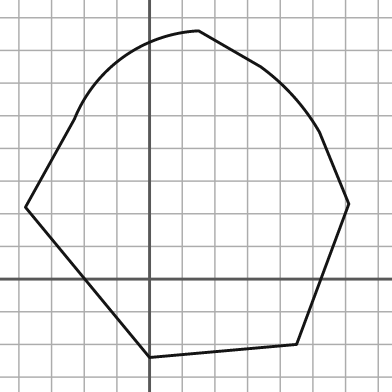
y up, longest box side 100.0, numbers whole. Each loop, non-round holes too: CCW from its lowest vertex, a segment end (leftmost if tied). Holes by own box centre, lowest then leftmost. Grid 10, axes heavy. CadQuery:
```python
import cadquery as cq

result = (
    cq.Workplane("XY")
    .moveTo(0.0, -24.0)
    .lineTo(45.0, -20.0)
    .lineTo(61.0, 23.0)
    .lineTo(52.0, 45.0)
    .threePointArc((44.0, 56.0), (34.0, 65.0))
    .lineTo(15.0, 76.0)
    .threePointArc((-8.0, 68.0), (-23.0, 49.0))
    .lineTo(-38.0, 22.0)
    .close()
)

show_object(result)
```